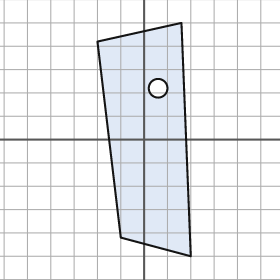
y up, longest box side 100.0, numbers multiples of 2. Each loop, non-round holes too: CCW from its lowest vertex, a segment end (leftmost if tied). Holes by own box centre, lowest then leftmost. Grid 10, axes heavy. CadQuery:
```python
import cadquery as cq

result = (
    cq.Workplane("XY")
    .moveTo(20.0, -50.0)
    .lineTo(16.0, 50.0)
    .lineTo(-20.0, 42.0)
    .lineTo(-10.0, -42.0)
    .close()
    .moveTo(6.0, 22.0)
    .circle(4.0)
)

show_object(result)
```